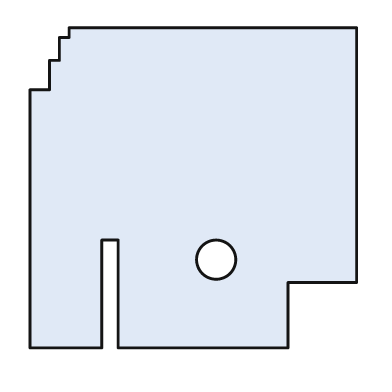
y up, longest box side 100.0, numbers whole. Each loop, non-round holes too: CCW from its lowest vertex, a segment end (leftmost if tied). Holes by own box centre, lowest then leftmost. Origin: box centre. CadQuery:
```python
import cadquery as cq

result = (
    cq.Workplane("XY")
    .moveTo(-50.0, -49.0)
    .lineTo(-28.0, -49.0)
    .lineTo(-28.0, -16.0)
    .lineTo(-23.0, -16.0)
    .lineTo(-23.0, -49.0)
    .lineTo(29.0, -49.0)
    .lineTo(29.0, -29.0)
    .lineTo(50.0, -29.0)
    .lineTo(50.0, 49.0)
    .lineTo(-38.0, 49.0)
    .lineTo(-38.0, 46.0)
    .lineTo(-41.0, 46.0)
    .lineTo(-41.0, 39.0)
    .lineTo(-44.0, 39.0)
    .lineTo(-44.0, 30.0)
    .lineTo(-50.0, 30.0)
    .close()
    .moveTo(7.0, -22.0)
    .circle(6.0)
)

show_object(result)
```